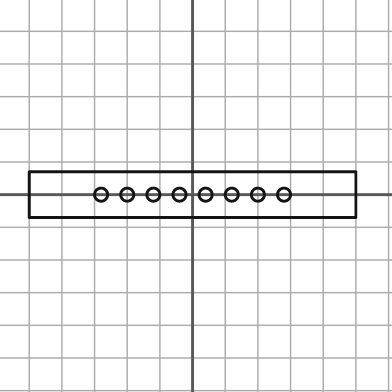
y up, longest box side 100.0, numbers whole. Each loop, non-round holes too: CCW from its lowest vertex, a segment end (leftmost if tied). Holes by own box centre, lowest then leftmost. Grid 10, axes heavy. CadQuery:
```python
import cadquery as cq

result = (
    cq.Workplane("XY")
    .moveTo(-50.0, -7.0)
    .lineTo(50.0, -7.0)
    .lineTo(50.0, 7.0)
    .lineTo(-50.0, 7.0)
    .close()
    .moveTo(-28.0, 0.0)
    .circle(2.0)
    .moveTo(-20.0, 0.0)
    .circle(2.0)
    .moveTo(-12.0, 0.0)
    .circle(2.0)
    .moveTo(-4.0, 0.0)
    .circle(2.0)
    .moveTo(4.0, 0.0)
    .circle(2.0)
    .moveTo(12.0, 0.0)
    .circle(2.0)
    .moveTo(20.0, 0.0)
    .circle(2.0)
    .moveTo(28.0, 0.0)
    .circle(2.0)
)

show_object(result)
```